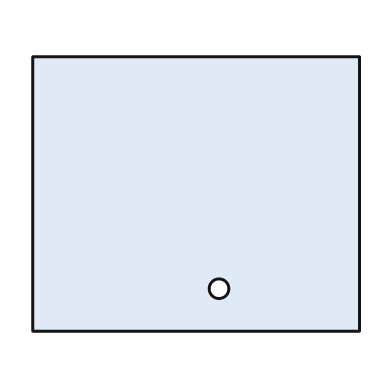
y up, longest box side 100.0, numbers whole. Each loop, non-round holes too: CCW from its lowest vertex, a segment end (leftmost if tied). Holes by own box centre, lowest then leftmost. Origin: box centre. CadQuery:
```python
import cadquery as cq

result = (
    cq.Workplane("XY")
    .moveTo(-50.0, -42.0)
    .lineTo(50.0, -42.0)
    .lineTo(50.0, 42.0)
    .lineTo(-50.0, 42.0)
    .close()
    .moveTo(7.0, -29.0)
    .circle(3.0)
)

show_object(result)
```